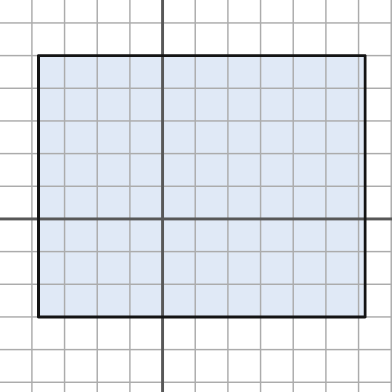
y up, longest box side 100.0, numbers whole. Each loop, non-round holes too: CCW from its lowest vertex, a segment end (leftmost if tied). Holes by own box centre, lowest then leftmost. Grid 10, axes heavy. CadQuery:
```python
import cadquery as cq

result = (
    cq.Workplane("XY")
    .moveTo(-38.0, -30.0)
    .lineTo(62.0, -30.0)
    .lineTo(62.0, 50.0)
    .lineTo(-38.0, 50.0)
    .close()
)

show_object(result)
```